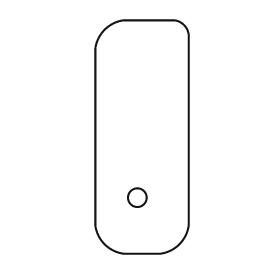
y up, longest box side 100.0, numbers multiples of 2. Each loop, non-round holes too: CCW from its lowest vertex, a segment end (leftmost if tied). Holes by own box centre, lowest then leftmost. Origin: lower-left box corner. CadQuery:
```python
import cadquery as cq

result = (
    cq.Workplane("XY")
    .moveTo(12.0, 0.0)
    .lineTo(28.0, 0.0)
    .threePointArc((36.0, 4.0), (40.0, 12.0))
    .lineTo(40.0, 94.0)
    .threePointArc((38.0, 98.0), (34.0, 100.0))
    .lineTo(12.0, 100.0)
    .threePointArc((4.0, 96.0), (0.0, 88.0))
    .lineTo(0.0, 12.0)
    .threePointArc((4.0, 4.0), (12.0, 0.0))
    .close()
    .moveTo(18.0, 24.0)
    .circle(4.0)
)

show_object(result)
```